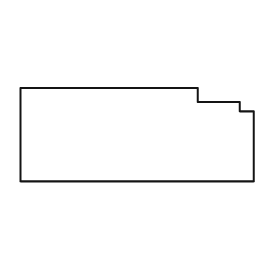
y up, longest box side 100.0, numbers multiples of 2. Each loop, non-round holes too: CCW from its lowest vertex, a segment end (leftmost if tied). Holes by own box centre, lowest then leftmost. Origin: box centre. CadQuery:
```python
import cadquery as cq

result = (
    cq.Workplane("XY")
    .moveTo(-50.0, -20.0)
    .lineTo(50.0, -20.0)
    .lineTo(50.0, 10.0)
    .lineTo(44.0, 10.0)
    .lineTo(44.0, 14.0)
    .lineTo(26.0, 14.0)
    .lineTo(26.0, 20.0)
    .lineTo(-50.0, 20.0)
    .close()
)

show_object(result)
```